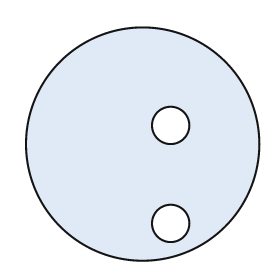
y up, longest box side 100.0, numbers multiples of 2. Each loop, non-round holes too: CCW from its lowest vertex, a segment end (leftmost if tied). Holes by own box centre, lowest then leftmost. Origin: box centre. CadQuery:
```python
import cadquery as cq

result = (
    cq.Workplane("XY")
    .moveTo(0.0, 0.0)
    .circle(50.0)
    .moveTo(12.0, -34.0)
    .circle(8.0)
    .moveTo(12.0, 8.0)
    .circle(8.0)
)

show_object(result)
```